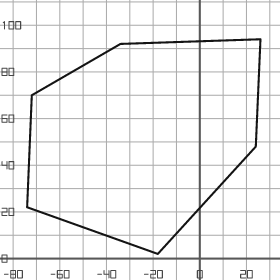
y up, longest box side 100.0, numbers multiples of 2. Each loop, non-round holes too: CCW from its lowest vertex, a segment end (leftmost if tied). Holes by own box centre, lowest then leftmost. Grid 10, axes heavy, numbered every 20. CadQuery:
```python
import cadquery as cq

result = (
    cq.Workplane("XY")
    .moveTo(-18.0, 2.0)
    .lineTo(24.0, 48.0)
    .lineTo(26.0, 94.0)
    .lineTo(-34.0, 92.0)
    .lineTo(-72.0, 70.0)
    .lineTo(-74.0, 22.0)
    .close()
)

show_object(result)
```